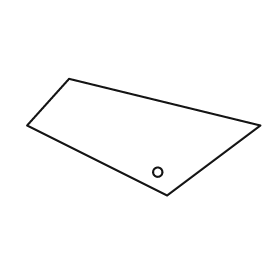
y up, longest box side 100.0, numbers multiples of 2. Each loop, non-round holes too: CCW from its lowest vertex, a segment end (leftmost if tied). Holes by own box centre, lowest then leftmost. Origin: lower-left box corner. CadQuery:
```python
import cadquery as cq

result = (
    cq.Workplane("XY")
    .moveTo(60.0, 0.0)
    .lineTo(100.0, 30.0)
    .lineTo(18.0, 50.0)
    .lineTo(0.0, 30.0)
    .close()
    .moveTo(56.0, 10.0)
    .circle(2.0)
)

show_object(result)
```